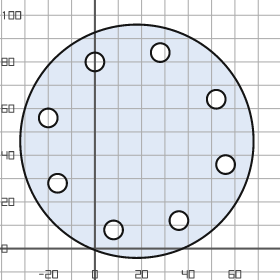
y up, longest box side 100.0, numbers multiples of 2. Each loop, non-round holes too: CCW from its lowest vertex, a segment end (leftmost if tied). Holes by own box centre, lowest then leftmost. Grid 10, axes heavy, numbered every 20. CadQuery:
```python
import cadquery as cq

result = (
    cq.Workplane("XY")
    .moveTo(18.0, 46.0)
    .circle(50.0)
    .moveTo(8.0, 8.0)
    .circle(4.0)
    .moveTo(36.0, 12.0)
    .circle(4.0)
    .moveTo(-16.0, 28.0)
    .circle(4.0)
    .moveTo(56.0, 36.0)
    .circle(4.0)
    .moveTo(-20.0, 56.0)
    .circle(4.0)
    .moveTo(52.0, 64.0)
    .circle(4.0)
    .moveTo(0.0, 80.0)
    .circle(4.0)
    .moveTo(28.0, 84.0)
    .circle(4.0)
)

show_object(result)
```